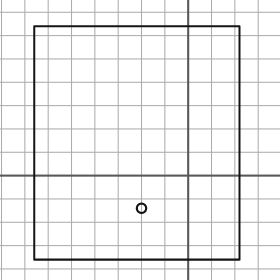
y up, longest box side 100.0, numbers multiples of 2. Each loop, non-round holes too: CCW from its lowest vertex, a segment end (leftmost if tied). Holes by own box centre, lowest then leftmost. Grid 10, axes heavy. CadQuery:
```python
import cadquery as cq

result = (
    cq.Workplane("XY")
    .moveTo(-66.0, -36.0)
    .lineTo(22.0, -36.0)
    .lineTo(22.0, 64.0)
    .lineTo(-66.0, 64.0)
    .close()
    .moveTo(-20.0, -14.0)
    .circle(2.0)
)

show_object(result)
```